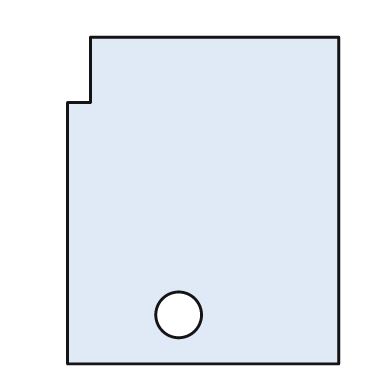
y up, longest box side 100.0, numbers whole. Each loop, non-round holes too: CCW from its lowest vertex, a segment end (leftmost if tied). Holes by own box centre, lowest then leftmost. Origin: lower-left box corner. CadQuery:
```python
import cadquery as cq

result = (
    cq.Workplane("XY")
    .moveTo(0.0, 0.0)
    .lineTo(83.0, 0.0)
    .lineTo(83.0, 100.0)
    .lineTo(7.0, 100.0)
    .lineTo(7.0, 80.0)
    .lineTo(0.0, 80.0)
    .close()
    .moveTo(34.0, 15.0)
    .circle(7.0)
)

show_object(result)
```